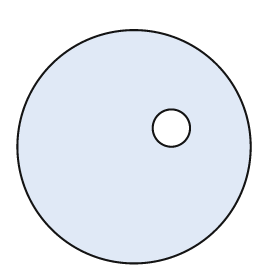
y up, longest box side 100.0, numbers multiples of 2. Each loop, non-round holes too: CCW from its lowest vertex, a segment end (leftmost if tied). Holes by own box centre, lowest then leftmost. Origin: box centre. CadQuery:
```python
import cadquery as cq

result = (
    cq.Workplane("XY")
    .moveTo(0.0, 0.0)
    .circle(50.0)
    .moveTo(16.0, 8.0)
    .circle(8.0)
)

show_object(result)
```